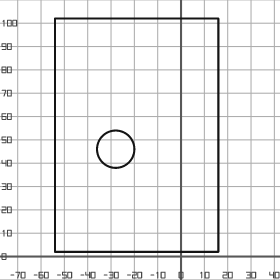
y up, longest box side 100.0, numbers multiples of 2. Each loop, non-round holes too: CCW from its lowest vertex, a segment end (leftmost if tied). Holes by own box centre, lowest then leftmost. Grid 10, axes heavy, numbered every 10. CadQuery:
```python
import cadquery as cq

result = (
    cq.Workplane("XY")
    .moveTo(-54.0, 2.0)
    .lineTo(16.0, 2.0)
    .lineTo(16.0, 102.0)
    .lineTo(-54.0, 102.0)
    .close()
    .moveTo(-28.0, 46.0)
    .circle(8.0)
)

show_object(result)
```